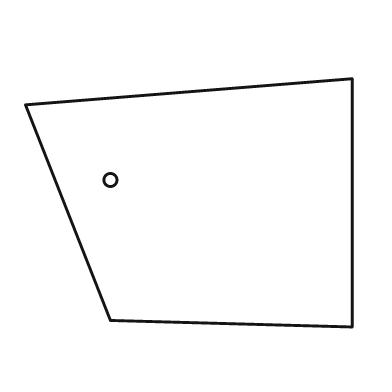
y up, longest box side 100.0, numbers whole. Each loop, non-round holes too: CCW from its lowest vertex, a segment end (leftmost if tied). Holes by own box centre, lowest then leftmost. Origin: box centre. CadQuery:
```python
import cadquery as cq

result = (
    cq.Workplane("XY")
    .moveTo(50.0, -38.0)
    .lineTo(50.0, 38.0)
    .lineTo(-50.0, 30.0)
    .lineTo(-24.0, -36.0)
    .close()
    .moveTo(-24.0, 7.0)
    .circle(2.0)
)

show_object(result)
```